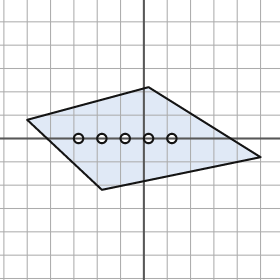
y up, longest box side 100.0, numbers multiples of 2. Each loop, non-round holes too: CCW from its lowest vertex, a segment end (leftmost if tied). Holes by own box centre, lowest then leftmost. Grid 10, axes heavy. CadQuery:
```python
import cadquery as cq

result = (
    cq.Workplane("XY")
    .moveTo(-18.0, -22.0)
    .lineTo(50.0, -8.0)
    .lineTo(2.0, 22.0)
    .lineTo(-50.0, 8.0)
    .close()
    .moveTo(-28.0, 0.0)
    .circle(2.0)
    .moveTo(-18.0, 0.0)
    .circle(2.0)
    .moveTo(-8.0, 0.0)
    .circle(2.0)
    .moveTo(2.0, 0.0)
    .circle(2.0)
    .moveTo(12.0, 0.0)
    .circle(2.0)
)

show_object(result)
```